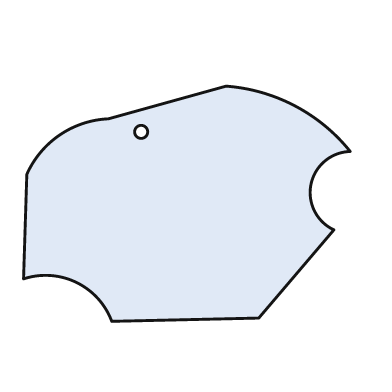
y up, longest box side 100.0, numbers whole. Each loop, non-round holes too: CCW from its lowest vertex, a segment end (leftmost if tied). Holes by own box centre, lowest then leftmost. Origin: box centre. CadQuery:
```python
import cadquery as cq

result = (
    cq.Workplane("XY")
    .moveTo(-23.0, -36.0)
    .lineTo(22.0, -35.0)
    .lineTo(45.0, -8.0)
    .threePointArc((38.0, 6.0), (50.0, 16.0))
    .threePointArc((33.0, 30.0), (12.0, 36.0))
    .lineTo(-24.0, 26.0)
    .threePointArc((-39.0, 21.0), (-49.0, 9.0))
    .lineTo(-50.0, -23.0)
    .threePointArc((-34.0, -24.0), (-23.0, -36.0))
    .close()
    .moveTo(-14.0, 22.0)
    .circle(2.0)
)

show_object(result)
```